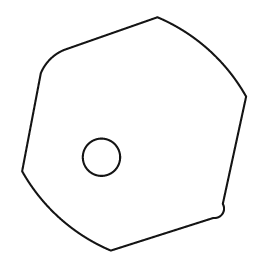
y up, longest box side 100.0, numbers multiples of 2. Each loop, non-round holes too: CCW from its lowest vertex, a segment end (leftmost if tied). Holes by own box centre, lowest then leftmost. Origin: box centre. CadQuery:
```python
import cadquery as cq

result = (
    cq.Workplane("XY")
    .moveTo(-10.0, -50.0)
    .lineTo(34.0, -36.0)
    .threePointArc((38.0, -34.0), (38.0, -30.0))
    .lineTo(48.0, 16.0)
    .threePointArc((32.0, 36.0), (10.0, 50.0))
    .lineTo(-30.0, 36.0)
    .threePointArc((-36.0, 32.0), (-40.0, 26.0))
    .lineTo(-48.0, -16.0)
    .threePointArc((-32.0, -36.0), (-10.0, -50.0))
    .close()
    .moveTo(-14.0, -10.0)
    .circle(8.0)
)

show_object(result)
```